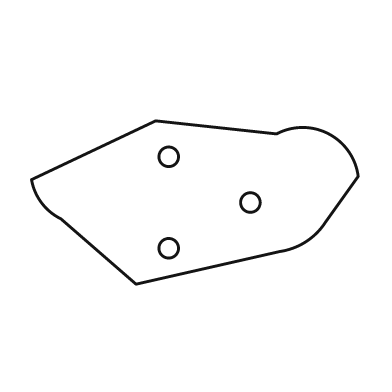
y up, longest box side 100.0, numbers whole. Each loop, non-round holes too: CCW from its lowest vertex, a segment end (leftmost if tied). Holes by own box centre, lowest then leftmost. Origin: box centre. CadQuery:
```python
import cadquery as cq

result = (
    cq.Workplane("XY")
    .moveTo(-18.0, -25.0)
    .lineTo(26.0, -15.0)
    .threePointArc((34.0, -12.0), (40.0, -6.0))
    .lineTo(50.0, 8.0)
    .threePointArc((41.0, 21.0), (25.0, 21.0))
    .lineTo(-12.0, 25.0)
    .lineTo(-50.0, 7.0)
    .threePointArc((-47.0, 0.0), (-41.0, -5.0))
    .close()
    .moveTo(-8.0, -14.0)
    .circle(3.0)
    .moveTo(17.0, 0.0)
    .circle(3.0)
    .moveTo(-8.0, 14.0)
    .circle(3.0)
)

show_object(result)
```